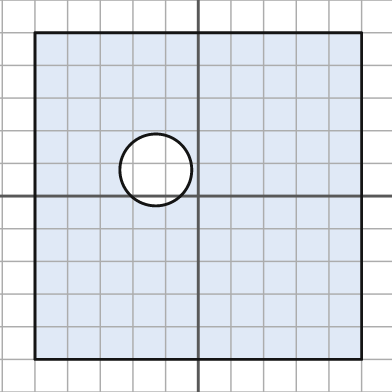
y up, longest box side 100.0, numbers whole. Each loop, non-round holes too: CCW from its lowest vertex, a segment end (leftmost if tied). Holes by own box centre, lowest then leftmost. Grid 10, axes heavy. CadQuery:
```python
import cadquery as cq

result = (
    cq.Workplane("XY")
    .moveTo(-50.0, -50.0)
    .lineTo(50.0, -50.0)
    .lineTo(50.0, 50.0)
    .lineTo(-50.0, 50.0)
    .close()
    .moveTo(-13.0, 8.0)
    .circle(11.0)
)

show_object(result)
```